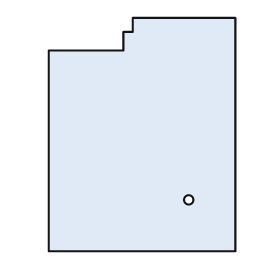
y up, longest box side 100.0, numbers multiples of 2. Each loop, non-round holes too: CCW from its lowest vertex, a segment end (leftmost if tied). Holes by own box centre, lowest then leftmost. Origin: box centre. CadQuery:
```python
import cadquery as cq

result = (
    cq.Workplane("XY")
    .moveTo(-40.0, -50.0)
    .lineTo(40.0, -50.0)
    .lineTo(40.0, 50.0)
    .lineTo(-4.0, 50.0)
    .lineTo(-4.0, 44.0)
    .lineTo(-8.0, 44.0)
    .lineTo(-8.0, 36.0)
    .lineTo(-40.0, 36.0)
    .close()
    .moveTo(20.0, -28.0)
    .circle(2.0)
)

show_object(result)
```